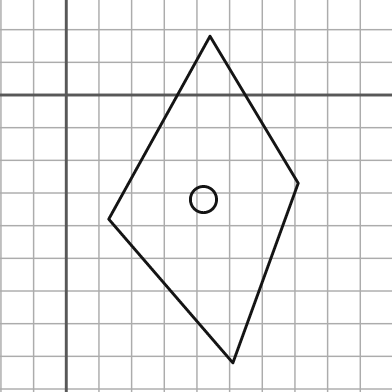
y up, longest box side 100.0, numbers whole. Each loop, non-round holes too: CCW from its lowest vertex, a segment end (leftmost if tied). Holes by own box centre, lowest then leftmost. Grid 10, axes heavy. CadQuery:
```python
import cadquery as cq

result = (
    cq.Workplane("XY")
    .moveTo(51.0, -82.0)
    .lineTo(71.0, -27.0)
    .lineTo(44.0, 18.0)
    .lineTo(13.0, -38.0)
    .close()
    .moveTo(42.0, -32.0)
    .circle(4.0)
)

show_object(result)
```